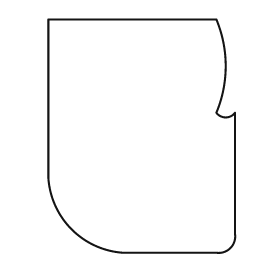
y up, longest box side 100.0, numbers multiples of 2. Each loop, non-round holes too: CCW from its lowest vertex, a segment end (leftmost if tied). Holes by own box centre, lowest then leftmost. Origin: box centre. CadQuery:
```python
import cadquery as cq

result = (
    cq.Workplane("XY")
    .moveTo(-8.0, -50.0)
    .lineTo(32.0, -50.0)
    .threePointArc((38.0, -48.0), (40.0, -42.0))
    .lineTo(40.0, 10.0)
    .threePointArc((36.0, 8.0), (32.0, 10.0))
    .threePointArc((36.0, 30.0), (32.0, 50.0))
    .lineTo(-40.0, 50.0)
    .lineTo(-40.0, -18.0)
    .threePointArc((-30.0, -40.0), (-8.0, -50.0))
    .close()
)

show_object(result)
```